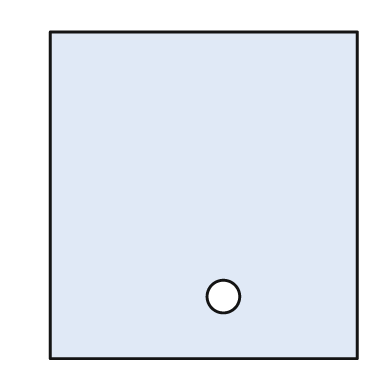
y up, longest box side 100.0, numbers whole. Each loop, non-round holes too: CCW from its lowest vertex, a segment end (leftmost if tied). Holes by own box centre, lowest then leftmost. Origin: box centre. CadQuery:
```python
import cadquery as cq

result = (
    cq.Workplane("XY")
    .moveTo(-47.0, -50.0)
    .lineTo(47.0, -50.0)
    .lineTo(47.0, 50.0)
    .lineTo(-47.0, 50.0)
    .close()
    .moveTo(6.0, -31.0)
    .circle(5.0)
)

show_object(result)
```